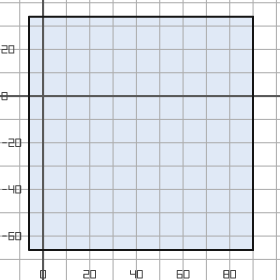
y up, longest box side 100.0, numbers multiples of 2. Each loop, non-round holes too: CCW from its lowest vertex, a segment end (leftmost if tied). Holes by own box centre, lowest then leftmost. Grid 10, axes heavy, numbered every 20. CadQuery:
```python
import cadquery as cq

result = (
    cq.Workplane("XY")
    .moveTo(-6.0, -66.0)
    .lineTo(90.0, -66.0)
    .lineTo(90.0, 34.0)
    .lineTo(-6.0, 34.0)
    .close()
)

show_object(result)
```